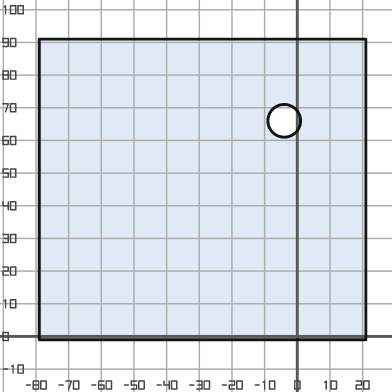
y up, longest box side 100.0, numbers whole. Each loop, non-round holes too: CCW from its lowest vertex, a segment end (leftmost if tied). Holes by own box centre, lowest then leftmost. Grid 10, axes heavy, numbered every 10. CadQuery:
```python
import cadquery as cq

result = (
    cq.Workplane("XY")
    .moveTo(-79.0, -1.0)
    .lineTo(21.0, -1.0)
    .lineTo(21.0, 91.0)
    .lineTo(-79.0, 91.0)
    .close()
    .moveTo(-4.0, 66.0)
    .circle(5.0)
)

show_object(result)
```